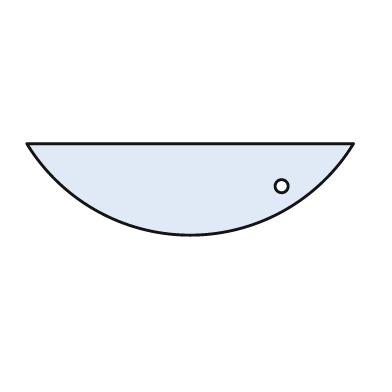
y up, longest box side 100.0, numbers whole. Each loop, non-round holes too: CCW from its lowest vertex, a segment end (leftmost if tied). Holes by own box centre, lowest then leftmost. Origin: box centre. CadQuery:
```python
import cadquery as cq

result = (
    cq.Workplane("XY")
    .moveTo(-50.0, 14.0)
    .threePointArc((0.0, -14.0), (50.0, 14.0))
    .close()
    .moveTo(28.0, 1.0)
    .circle(2.0)
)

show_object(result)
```